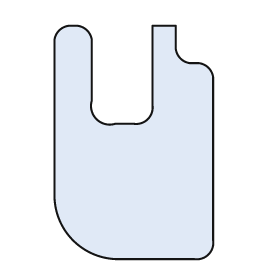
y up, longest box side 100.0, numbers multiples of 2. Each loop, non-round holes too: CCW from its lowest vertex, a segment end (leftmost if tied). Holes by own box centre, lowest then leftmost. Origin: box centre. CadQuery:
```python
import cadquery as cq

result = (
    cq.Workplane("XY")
    .moveTo(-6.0, -50.0)
    .lineTo(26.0, -50.0)
    .threePointArc((32.0, -48.0), (34.0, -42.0))
    .lineTo(34.0, 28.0)
    .threePointArc((32.0, 32.0), (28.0, 34.0))
    .lineTo(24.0, 34.0)
    .threePointArc((20.0, 36.0), (18.0, 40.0))
    .lineTo(18.0, 50.0)
    .lineTo(8.0, 50.0)
    .lineTo(8.0, 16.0)
    .threePointArc((6.0, 10.0), (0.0, 8.0))
    .lineTo(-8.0, 8.0)
    .threePointArc((-16.0, 10.0), (-18.0, 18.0))
    .lineTo(-18.0, 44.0)
    .threePointArc((-20.0, 48.0), (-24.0, 50.0))
    .lineTo(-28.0, 50.0)
    .threePointArc((-32.0, 48.0), (-34.0, 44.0))
    .lineTo(-34.0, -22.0)
    .threePointArc((-26.0, -42.0), (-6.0, -50.0))
    .close()
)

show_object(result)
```